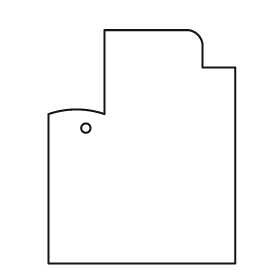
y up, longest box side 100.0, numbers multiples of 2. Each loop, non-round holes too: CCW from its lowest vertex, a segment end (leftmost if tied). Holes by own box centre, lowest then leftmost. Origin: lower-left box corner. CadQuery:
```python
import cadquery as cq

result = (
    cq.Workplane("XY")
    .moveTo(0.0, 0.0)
    .lineTo(80.0, 0.0)
    .lineTo(80.0, 84.0)
    .lineTo(66.0, 84.0)
    .lineTo(66.0, 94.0)
    .threePointArc((64.0, 98.0), (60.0, 100.0))
    .lineTo(24.0, 100.0)
    .lineTo(24.0, 64.0)
    .threePointArc((12.0, 66.0), (0.0, 64.0))
    .close()
    .moveTo(16.0, 58.0)
    .circle(2.0)
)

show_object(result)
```